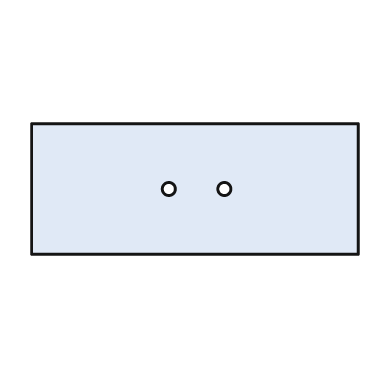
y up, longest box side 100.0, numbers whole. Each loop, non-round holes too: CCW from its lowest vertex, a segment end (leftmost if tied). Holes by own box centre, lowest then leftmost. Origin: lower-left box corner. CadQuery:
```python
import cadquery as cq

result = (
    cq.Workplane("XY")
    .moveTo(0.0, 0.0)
    .lineTo(100.0, 0.0)
    .lineTo(100.0, 40.0)
    .lineTo(0.0, 40.0)
    .close()
    .moveTo(42.0, 20.0)
    .circle(2.0)
    .moveTo(59.0, 20.0)
    .circle(2.0)
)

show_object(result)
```